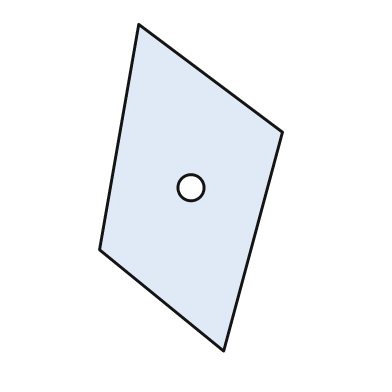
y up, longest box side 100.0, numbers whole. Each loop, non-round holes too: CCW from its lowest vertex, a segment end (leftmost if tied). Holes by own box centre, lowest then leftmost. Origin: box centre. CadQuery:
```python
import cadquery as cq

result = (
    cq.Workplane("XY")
    .moveTo(10.0, -50.0)
    .lineTo(28.0, 17.0)
    .lineTo(-16.0, 50.0)
    .lineTo(-28.0, -19.0)
    .close()
    .moveTo(0.0, 0.0)
    .circle(4.0)
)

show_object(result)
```